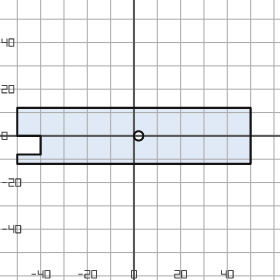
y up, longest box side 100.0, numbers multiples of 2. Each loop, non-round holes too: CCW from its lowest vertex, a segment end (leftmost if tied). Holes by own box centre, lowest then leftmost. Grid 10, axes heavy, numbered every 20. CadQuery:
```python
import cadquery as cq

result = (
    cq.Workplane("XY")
    .moveTo(-50.0, -12.0)
    .lineTo(50.0, -12.0)
    .lineTo(50.0, 12.0)
    .lineTo(-50.0, 12.0)
    .lineTo(-50.0, 0.0)
    .lineTo(-40.0, 0.0)
    .lineTo(-40.0, -8.0)
    .lineTo(-50.0, -8.0)
    .close()
    .moveTo(2.0, 0.0)
    .circle(2.0)
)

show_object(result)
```